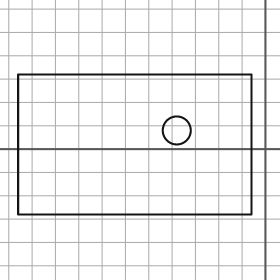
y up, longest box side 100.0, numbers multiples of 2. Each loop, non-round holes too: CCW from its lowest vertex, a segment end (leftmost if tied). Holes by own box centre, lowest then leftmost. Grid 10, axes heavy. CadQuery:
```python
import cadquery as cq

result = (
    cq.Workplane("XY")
    .moveTo(-106.0, -28.0)
    .lineTo(-6.0, -28.0)
    .lineTo(-6.0, 32.0)
    .lineTo(-106.0, 32.0)
    .close()
    .moveTo(-38.0, 8.0)
    .circle(6.0)
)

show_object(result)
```